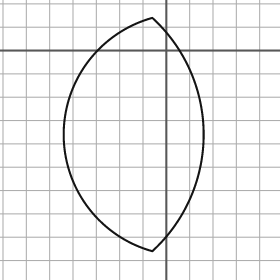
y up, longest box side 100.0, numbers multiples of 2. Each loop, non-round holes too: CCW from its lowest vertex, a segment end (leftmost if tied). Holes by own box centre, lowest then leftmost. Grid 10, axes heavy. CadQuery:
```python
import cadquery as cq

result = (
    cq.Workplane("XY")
    .moveTo(-6.0, -86.0)
    .threePointArc((16.0, -36.0), (-6.0, 14.0))
    .threePointArc((-44.0, -36.0), (-6.0, -86.0))
    .close()
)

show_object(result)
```